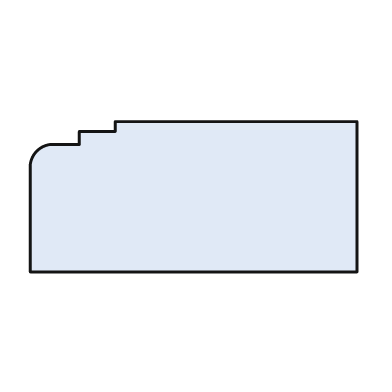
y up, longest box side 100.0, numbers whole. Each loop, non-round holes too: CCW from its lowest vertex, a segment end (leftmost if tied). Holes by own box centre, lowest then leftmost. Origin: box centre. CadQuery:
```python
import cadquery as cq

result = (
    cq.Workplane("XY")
    .moveTo(-50.0, -23.0)
    .lineTo(50.0, -23.0)
    .lineTo(50.0, 23.0)
    .lineTo(-24.0, 23.0)
    .lineTo(-24.0, 20.0)
    .lineTo(-35.0, 20.0)
    .lineTo(-35.0, 16.0)
    .lineTo(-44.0, 16.0)
    .threePointArc((-48.0, 14.0), (-50.0, 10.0))
    .close()
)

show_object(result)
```